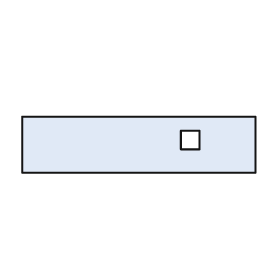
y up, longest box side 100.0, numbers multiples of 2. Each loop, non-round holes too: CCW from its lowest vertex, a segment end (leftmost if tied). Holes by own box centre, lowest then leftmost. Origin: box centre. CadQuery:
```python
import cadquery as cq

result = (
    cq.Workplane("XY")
    .moveTo(-50.0, -12.0)
    .lineTo(50.0, -12.0)
    .lineTo(50.0, 12.0)
    .lineTo(-50.0, 12.0)
    .close()
    .moveTo(18.0, -2.0)
    .lineTo(26.0, -2.0)
    .lineTo(26.0, 6.0)
    .lineTo(18.0, 6.0)
    .close()
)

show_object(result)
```